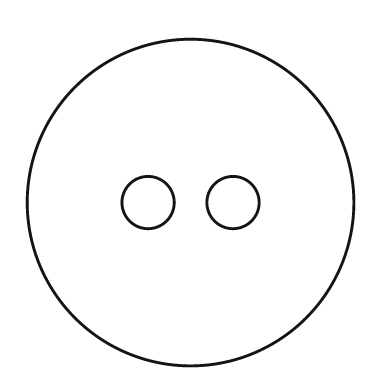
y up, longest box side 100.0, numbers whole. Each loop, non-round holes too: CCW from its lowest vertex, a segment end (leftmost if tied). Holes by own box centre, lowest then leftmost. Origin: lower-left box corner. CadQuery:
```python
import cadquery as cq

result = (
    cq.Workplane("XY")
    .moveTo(50.0, 50.0)
    .circle(50.0)
    .moveTo(37.0, 50.0)
    .circle(8.0)
    .moveTo(63.0, 50.0)
    .circle(8.0)
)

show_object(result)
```